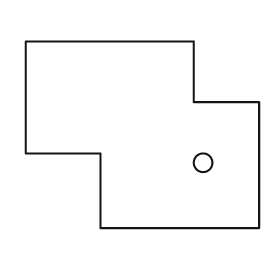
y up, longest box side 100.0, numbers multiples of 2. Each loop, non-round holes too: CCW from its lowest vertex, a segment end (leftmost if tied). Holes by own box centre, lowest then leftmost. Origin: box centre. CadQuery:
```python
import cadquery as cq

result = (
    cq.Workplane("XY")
    .moveTo(-18.0, -40.0)
    .lineTo(50.0, -40.0)
    .lineTo(50.0, 14.0)
    .lineTo(22.0, 14.0)
    .lineTo(22.0, 40.0)
    .lineTo(-50.0, 40.0)
    .lineTo(-50.0, -8.0)
    .lineTo(-18.0, -8.0)
    .close()
    .moveTo(26.0, -12.0)
    .circle(4.0)
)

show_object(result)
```